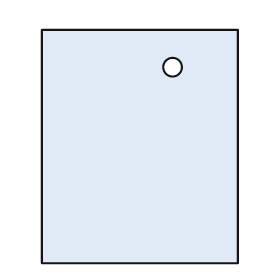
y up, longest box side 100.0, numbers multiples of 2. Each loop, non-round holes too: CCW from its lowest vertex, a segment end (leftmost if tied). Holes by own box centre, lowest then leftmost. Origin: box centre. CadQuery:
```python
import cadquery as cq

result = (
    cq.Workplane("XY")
    .moveTo(-42.0, -50.0)
    .lineTo(42.0, -50.0)
    .lineTo(42.0, 50.0)
    .lineTo(-42.0, 50.0)
    .close()
    .moveTo(14.0, 34.0)
    .circle(4.0)
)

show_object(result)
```